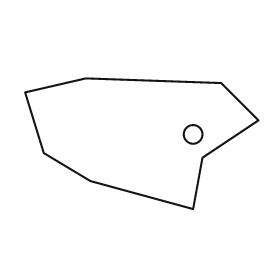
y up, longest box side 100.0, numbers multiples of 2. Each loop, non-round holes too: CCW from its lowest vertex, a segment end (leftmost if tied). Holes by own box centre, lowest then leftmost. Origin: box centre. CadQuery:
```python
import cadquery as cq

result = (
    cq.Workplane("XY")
    .moveTo(22.0, -28.0)
    .lineTo(26.0, -6.0)
    .lineTo(50.0, 10.0)
    .lineTo(34.0, 26.0)
    .lineTo(-24.0, 28.0)
    .lineTo(-50.0, 22.0)
    .lineTo(-42.0, -4.0)
    .lineTo(-22.0, -16.0)
    .close()
    .moveTo(22.0, 4.0)
    .circle(4.0)
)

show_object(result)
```